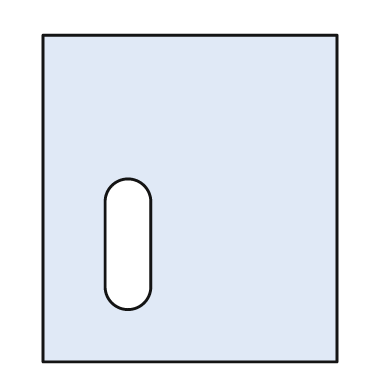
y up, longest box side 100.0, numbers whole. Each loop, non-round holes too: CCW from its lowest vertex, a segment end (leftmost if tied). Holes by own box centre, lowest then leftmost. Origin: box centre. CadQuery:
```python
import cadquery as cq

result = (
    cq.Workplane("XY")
    .moveTo(-45.0, -50.0)
    .lineTo(45.0, -50.0)
    .lineTo(45.0, 50.0)
    .lineTo(-45.0, 50.0)
    .close()
    .moveTo(-26.0, -27.0)
    .threePointArc((-19.0, -34.0), (-12.0, -27.0))
    .lineTo(-12.0, -1.0)
    .threePointArc((-19.0, 6.0), (-26.0, -1.0))
    .close()
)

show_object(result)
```